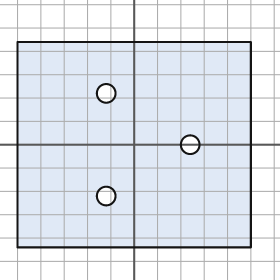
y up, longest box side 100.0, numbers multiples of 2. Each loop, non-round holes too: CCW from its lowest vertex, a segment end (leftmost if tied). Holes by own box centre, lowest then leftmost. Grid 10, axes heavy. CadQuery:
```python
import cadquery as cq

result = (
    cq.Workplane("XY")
    .moveTo(-50.0, -44.0)
    .lineTo(50.0, -44.0)
    .lineTo(50.0, 44.0)
    .lineTo(-50.0, 44.0)
    .close()
    .moveTo(-12.0, -22.0)
    .circle(4.0)
    .moveTo(24.0, 0.0)
    .circle(4.0)
    .moveTo(-12.0, 22.0)
    .circle(4.0)
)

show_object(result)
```